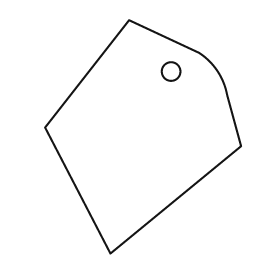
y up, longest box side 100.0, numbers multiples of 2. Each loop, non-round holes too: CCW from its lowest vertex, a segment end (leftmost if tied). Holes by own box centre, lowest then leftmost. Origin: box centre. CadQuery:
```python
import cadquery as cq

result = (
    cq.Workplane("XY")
    .moveTo(-14.0, -50.0)
    .lineTo(42.0, -4.0)
    .lineTo(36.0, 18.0)
    .threePointArc((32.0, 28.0), (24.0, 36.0))
    .lineTo(-6.0, 50.0)
    .lineTo(-42.0, 4.0)
    .close()
    .moveTo(12.0, 28.0)
    .circle(4.0)
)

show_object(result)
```